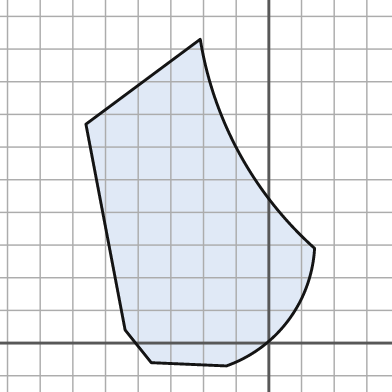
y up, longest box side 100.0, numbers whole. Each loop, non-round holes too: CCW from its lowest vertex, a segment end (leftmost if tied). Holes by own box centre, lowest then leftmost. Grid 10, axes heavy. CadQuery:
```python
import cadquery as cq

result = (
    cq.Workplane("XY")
    .moveTo(-13.0, -7.0)
    .threePointArc((6.0, 7.0), (14.0, 29.0))
    .threePointArc((-9.0, 58.0), (-21.0, 93.0))
    .lineTo(-56.0, 67.0)
    .lineTo(-44.0, 4.0)
    .lineTo(-36.0, -6.0)
    .close()
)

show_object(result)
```